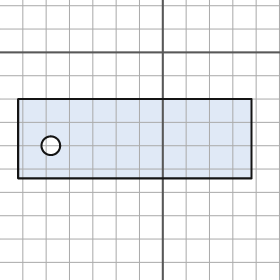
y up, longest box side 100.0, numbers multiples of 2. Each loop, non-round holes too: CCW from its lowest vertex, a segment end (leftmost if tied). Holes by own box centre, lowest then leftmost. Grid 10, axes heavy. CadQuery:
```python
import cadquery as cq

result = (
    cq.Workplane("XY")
    .moveTo(-62.0, -54.0)
    .lineTo(38.0, -54.0)
    .lineTo(38.0, -20.0)
    .lineTo(-62.0, -20.0)
    .close()
    .moveTo(-48.0, -40.0)
    .circle(4.0)
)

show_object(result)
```